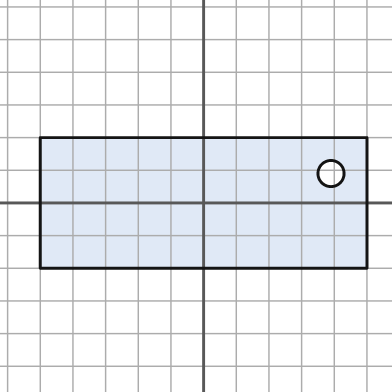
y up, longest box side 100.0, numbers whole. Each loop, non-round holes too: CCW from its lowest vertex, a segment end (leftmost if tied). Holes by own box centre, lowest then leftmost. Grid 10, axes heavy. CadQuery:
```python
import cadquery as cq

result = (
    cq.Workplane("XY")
    .moveTo(-50.0, -20.0)
    .lineTo(50.0, -20.0)
    .lineTo(50.0, 20.0)
    .lineTo(-50.0, 20.0)
    .close()
    .moveTo(39.0, 9.0)
    .circle(4.0)
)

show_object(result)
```